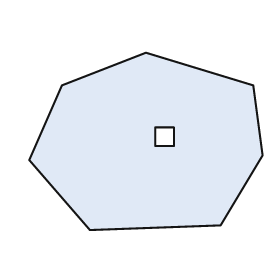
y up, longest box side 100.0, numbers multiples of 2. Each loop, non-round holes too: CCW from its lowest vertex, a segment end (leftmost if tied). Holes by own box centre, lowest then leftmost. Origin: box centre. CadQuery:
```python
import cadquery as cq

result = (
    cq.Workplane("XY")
    .moveTo(-24.0, -38.0)
    .lineTo(32.0, -36.0)
    .lineTo(50.0, -6.0)
    .lineTo(46.0, 24.0)
    .lineTo(0.0, 38.0)
    .lineTo(-36.0, 24.0)
    .lineTo(-50.0, -8.0)
    .close()
    .moveTo(4.0, -2.0)
    .lineTo(12.0, -2.0)
    .lineTo(12.0, 6.0)
    .lineTo(4.0, 6.0)
    .close()
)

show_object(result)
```